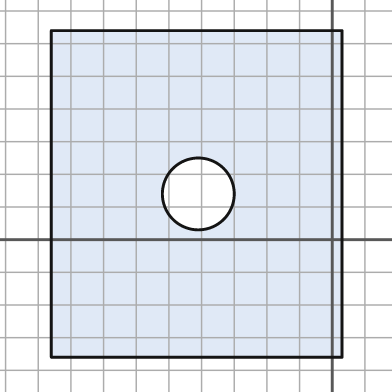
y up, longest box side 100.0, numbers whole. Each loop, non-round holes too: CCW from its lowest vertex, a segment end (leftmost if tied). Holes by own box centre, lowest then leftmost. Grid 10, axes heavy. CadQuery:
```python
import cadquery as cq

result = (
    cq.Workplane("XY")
    .moveTo(-86.0, -36.0)
    .lineTo(3.0, -36.0)
    .lineTo(3.0, 64.0)
    .lineTo(-86.0, 64.0)
    .close()
    .moveTo(-41.0, 14.0)
    .circle(11.0)
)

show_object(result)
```